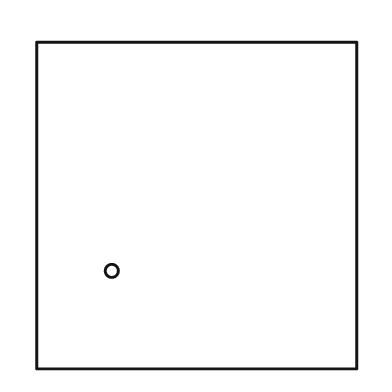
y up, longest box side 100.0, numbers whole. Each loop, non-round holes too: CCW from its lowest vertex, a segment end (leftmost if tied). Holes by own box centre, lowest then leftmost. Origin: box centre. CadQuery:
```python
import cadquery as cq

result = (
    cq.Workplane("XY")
    .moveTo(-49.0, -50.0)
    .lineTo(49.0, -50.0)
    .lineTo(49.0, 50.0)
    .lineTo(-49.0, 50.0)
    .close()
    .moveTo(-26.0, -20.0)
    .circle(2.0)
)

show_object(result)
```